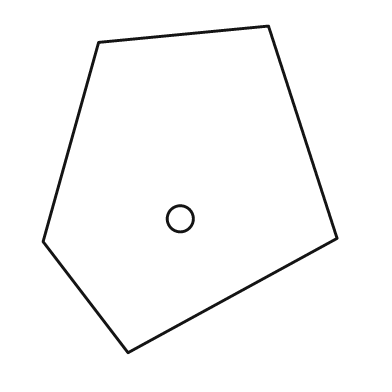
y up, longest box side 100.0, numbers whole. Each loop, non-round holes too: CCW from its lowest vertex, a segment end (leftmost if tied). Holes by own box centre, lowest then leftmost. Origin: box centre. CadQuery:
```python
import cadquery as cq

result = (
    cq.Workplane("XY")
    .moveTo(-19.0, -50.0)
    .lineTo(45.0, -15.0)
    .lineTo(24.0, 50.0)
    .lineTo(-28.0, 45.0)
    .lineTo(-45.0, -16.0)
    .close()
    .moveTo(-3.0, -9.0)
    .circle(4.0)
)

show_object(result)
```